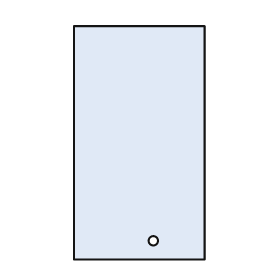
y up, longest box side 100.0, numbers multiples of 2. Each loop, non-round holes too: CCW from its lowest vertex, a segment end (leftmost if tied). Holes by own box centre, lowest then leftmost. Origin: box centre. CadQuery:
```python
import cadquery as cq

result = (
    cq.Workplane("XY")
    .moveTo(-28.0, -50.0)
    .lineTo(28.0, -50.0)
    .lineTo(28.0, 50.0)
    .lineTo(-28.0, 50.0)
    .close()
    .moveTo(6.0, -42.0)
    .circle(2.0)
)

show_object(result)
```